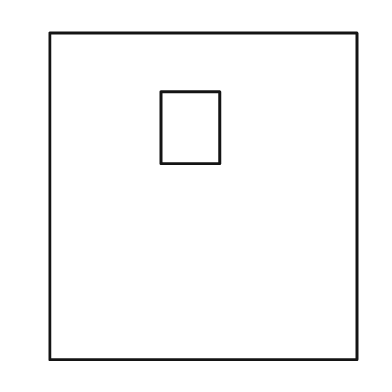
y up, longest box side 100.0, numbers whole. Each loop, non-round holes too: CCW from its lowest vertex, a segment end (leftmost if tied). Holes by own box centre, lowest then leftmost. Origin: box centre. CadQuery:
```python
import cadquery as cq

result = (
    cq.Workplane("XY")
    .moveTo(-47.0, -50.0)
    .lineTo(47.0, -50.0)
    .lineTo(47.0, 50.0)
    .lineTo(-47.0, 50.0)
    .close()
    .moveTo(-13.0, 10.0)
    .lineTo(5.0, 10.0)
    .lineTo(5.0, 32.0)
    .lineTo(-13.0, 32.0)
    .close()
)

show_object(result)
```